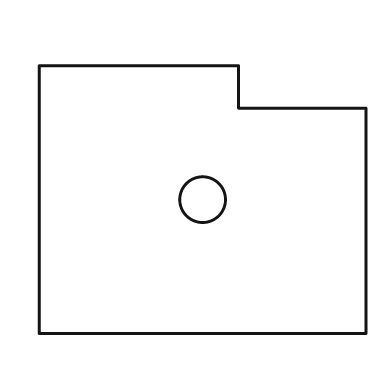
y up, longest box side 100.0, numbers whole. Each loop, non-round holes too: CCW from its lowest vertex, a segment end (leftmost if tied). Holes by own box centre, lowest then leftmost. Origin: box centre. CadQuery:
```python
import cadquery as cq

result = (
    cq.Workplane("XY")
    .moveTo(-50.0, -41.0)
    .lineTo(50.0, -41.0)
    .lineTo(50.0, 28.0)
    .lineTo(11.0, 28.0)
    .lineTo(11.0, 41.0)
    .lineTo(-50.0, 41.0)
    .close()
    .moveTo(0.0, 0.0)
    .circle(7.0)
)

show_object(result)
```